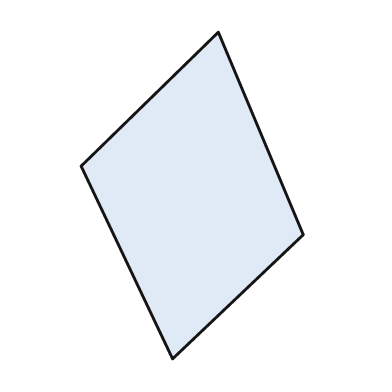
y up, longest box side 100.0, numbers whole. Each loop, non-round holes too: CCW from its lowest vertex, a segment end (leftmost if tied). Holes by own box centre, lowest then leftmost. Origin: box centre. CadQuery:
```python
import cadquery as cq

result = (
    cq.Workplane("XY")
    .moveTo(-6.0, -50.0)
    .lineTo(34.0, -12.0)
    .lineTo(8.0, 50.0)
    .lineTo(-34.0, 9.0)
    .close()
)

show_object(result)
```